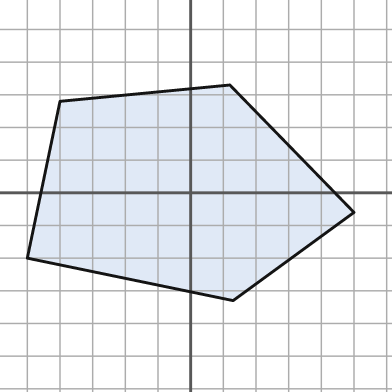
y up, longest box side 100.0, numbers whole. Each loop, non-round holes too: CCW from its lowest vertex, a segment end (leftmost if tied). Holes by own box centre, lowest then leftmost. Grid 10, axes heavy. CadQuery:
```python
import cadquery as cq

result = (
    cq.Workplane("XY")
    .moveTo(13.0, -33.0)
    .lineTo(50.0, -6.0)
    .lineTo(12.0, 33.0)
    .lineTo(-40.0, 28.0)
    .lineTo(-50.0, -20.0)
    .close()
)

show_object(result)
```